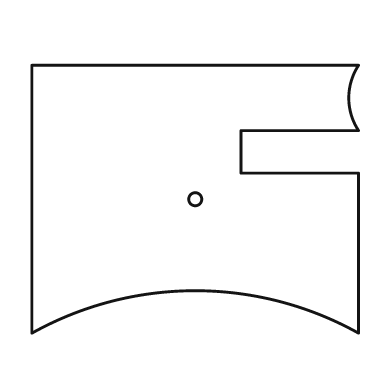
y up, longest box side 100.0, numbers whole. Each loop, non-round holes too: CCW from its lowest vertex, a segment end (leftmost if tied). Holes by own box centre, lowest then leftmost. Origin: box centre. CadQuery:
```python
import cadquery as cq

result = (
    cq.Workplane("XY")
    .moveTo(-50.0, -41.0)
    .threePointArc((0.0, -28.0), (50.0, -41.0))
    .lineTo(50.0, 8.0)
    .lineTo(14.0, 8.0)
    .lineTo(14.0, 21.0)
    .lineTo(50.0, 21.0)
    .threePointArc((47.0, 31.0), (50.0, 41.0))
    .lineTo(-50.0, 41.0)
    .close()
    .moveTo(0.0, 0.0)
    .circle(2.0)
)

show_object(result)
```